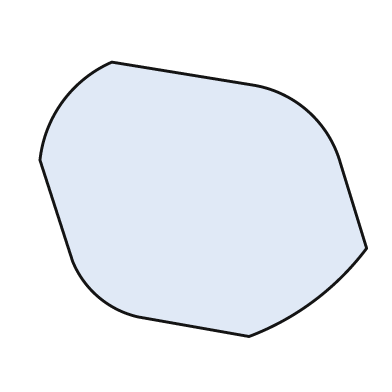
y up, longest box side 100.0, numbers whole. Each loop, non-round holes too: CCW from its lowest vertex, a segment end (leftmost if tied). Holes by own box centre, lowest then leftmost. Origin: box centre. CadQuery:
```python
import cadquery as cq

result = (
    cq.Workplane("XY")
    .moveTo(14.0, -42.0)
    .threePointArc((34.0, -31.0), (50.0, -15.0))
    .lineTo(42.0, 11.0)
    .threePointArc((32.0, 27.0), (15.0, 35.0))
    .lineTo(-28.0, 42.0)
    .threePointArc((-43.0, 30.0), (-50.0, 12.0))
    .lineTo(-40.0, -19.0)
    .threePointArc((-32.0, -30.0), (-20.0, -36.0))
    .close()
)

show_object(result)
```